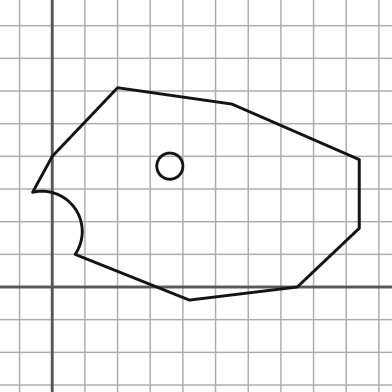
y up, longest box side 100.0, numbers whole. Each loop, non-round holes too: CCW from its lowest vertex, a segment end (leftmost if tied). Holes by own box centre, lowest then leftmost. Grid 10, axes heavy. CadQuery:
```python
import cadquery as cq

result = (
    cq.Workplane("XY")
    .moveTo(42.0, -4.0)
    .lineTo(75.0, 0.0)
    .lineTo(94.0, 18.0)
    .lineTo(94.0, 39.0)
    .lineTo(55.0, 56.0)
    .lineTo(20.0, 61.0)
    .lineTo(0.0, 40.0)
    .lineTo(-6.0, 29.0)
    .threePointArc((7.0, 24.0), (7.0, 10.0))
    .close()
    .moveTo(36.0, 37.0)
    .circle(4.0)
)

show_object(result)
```